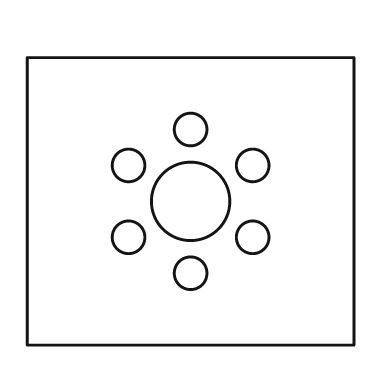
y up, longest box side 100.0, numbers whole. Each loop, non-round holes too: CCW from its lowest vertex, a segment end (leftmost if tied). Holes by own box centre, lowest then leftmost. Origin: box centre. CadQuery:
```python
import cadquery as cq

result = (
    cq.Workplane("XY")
    .moveTo(-50.0, -44.0)
    .lineTo(50.0, -44.0)
    .lineTo(50.0, 44.0)
    .lineTo(-50.0, 44.0)
    .close()
    .moveTo(0.0, -22.0)
    .circle(5.0)
    .moveTo(-19.0, -11.0)
    .circle(5.0)
    .moveTo(19.0, -11.0)
    .circle(5.0)
    .moveTo(0.0, 0.0)
    .circle(12.0)
    .moveTo(-19.0, 11.0)
    .circle(5.0)
    .moveTo(19.0, 11.0)
    .circle(5.0)
    .moveTo(0.0, 22.0)
    .circle(5.0)
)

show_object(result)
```